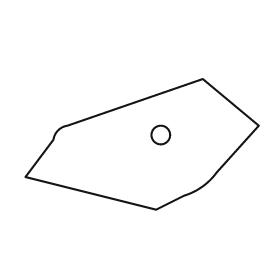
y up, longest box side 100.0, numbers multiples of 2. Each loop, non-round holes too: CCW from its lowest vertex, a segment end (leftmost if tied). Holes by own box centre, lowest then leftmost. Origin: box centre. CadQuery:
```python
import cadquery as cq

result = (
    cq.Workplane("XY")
    .moveTo(6.0, -28.0)
    .lineTo(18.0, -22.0)
    .threePointArc((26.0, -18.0), (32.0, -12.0))
    .lineTo(50.0, 8.0)
    .lineTo(26.0, 28.0)
    .lineTo(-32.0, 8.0)
    .threePointArc((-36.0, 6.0), (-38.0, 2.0))
    .lineTo(-50.0, -14.0)
    .close()
    .moveTo(8.0, 4.0)
    .circle(4.0)
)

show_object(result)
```